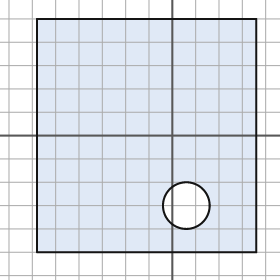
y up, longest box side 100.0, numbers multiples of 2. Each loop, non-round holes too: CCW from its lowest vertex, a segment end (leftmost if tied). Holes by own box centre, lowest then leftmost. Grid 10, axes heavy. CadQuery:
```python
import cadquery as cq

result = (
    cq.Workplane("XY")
    .moveTo(-58.0, -50.0)
    .lineTo(36.0, -50.0)
    .lineTo(36.0, 50.0)
    .lineTo(-58.0, 50.0)
    .close()
    .moveTo(6.0, -30.0)
    .circle(10.0)
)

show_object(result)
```